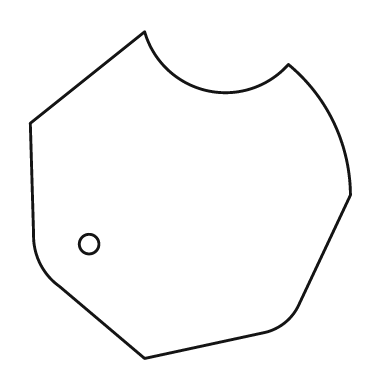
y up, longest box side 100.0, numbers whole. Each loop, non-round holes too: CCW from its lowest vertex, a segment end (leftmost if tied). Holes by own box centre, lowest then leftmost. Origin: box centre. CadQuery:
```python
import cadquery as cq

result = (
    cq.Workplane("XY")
    .moveTo(-14.0, -50.0)
    .lineTo(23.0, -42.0)
    .threePointArc((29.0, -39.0), (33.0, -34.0))
    .lineTo(49.0, 0.0)
    .threePointArc((44.0, 22.0), (30.0, 40.0))
    .threePointArc((5.0, 32.0), (-14.0, 50.0))
    .lineTo(-49.0, 22.0)
    .lineTo(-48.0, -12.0)
    .threePointArc((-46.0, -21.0), (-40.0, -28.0))
    .close()
    .moveTo(-31.0, -15.0)
    .circle(3.0)
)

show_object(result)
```